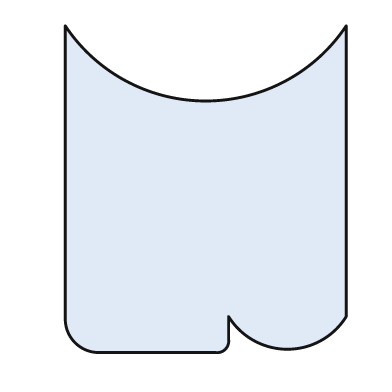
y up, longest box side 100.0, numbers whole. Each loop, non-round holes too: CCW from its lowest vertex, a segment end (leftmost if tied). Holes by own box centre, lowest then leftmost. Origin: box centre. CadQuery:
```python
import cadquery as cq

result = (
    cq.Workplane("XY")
    .moveTo(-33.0, -50.0)
    .lineTo(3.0, -50.0)
    .threePointArc((6.0, -49.0), (7.0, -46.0))
    .lineTo(7.0, -39.0)
    .threePointArc((25.0, -49.0), (43.0, -39.0))
    .lineTo(43.0, 50.0)
    .threePointArc((0.0, 27.0), (-43.0, 50.0))
    .lineTo(-43.0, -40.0)
    .threePointArc((-40.0, -47.0), (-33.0, -50.0))
    .close()
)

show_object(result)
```